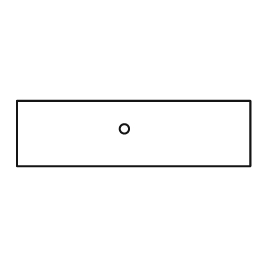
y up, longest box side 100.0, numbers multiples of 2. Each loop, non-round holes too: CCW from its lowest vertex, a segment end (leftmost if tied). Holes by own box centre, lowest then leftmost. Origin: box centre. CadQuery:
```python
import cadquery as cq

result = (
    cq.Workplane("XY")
    .moveTo(-50.0, -14.0)
    .lineTo(50.0, -14.0)
    .lineTo(50.0, 14.0)
    .lineTo(-50.0, 14.0)
    .close()
    .moveTo(-4.0, 2.0)
    .circle(2.0)
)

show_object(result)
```